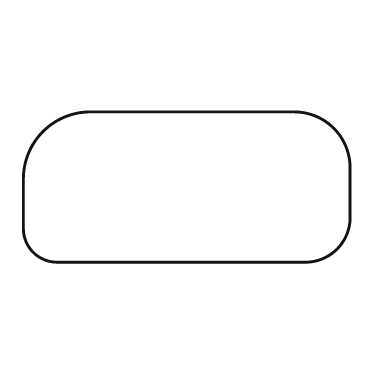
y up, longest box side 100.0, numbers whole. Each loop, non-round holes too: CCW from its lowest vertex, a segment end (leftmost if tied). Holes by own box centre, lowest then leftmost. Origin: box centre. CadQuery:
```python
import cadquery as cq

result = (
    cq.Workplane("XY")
    .moveTo(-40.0, -23.0)
    .lineTo(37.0, -23.0)
    .threePointArc((46.0, -19.0), (50.0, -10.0))
    .lineTo(50.0, 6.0)
    .threePointArc((45.0, 18.0), (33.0, 23.0))
    .lineTo(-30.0, 23.0)
    .threePointArc((-44.0, 17.0), (-50.0, 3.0))
    .lineTo(-50.0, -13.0)
    .threePointArc((-47.0, -20.0), (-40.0, -23.0))
    .close()
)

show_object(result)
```